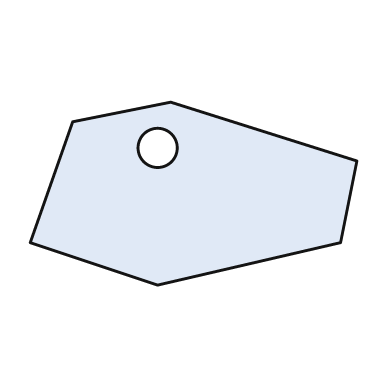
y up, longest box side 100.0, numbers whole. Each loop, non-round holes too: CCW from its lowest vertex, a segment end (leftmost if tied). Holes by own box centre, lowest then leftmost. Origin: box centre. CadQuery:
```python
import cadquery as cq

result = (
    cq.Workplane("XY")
    .moveTo(-11.0, -28.0)
    .lineTo(45.0, -15.0)
    .lineTo(50.0, 10.0)
    .lineTo(-7.0, 28.0)
    .lineTo(-37.0, 22.0)
    .lineTo(-50.0, -15.0)
    .close()
    .moveTo(-11.0, 14.0)
    .circle(6.0)
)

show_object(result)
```